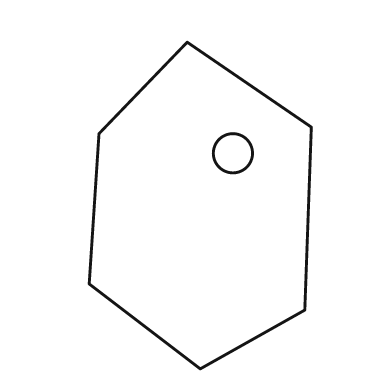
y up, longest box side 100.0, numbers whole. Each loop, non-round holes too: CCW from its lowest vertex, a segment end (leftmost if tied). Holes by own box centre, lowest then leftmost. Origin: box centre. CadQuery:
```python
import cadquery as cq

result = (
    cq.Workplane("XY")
    .moveTo(0.0, -50.0)
    .lineTo(32.0, -32.0)
    .lineTo(34.0, 24.0)
    .lineTo(-4.0, 50.0)
    .lineTo(-31.0, 22.0)
    .lineTo(-34.0, -24.0)
    .close()
    .moveTo(10.0, 16.0)
    .circle(6.0)
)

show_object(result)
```